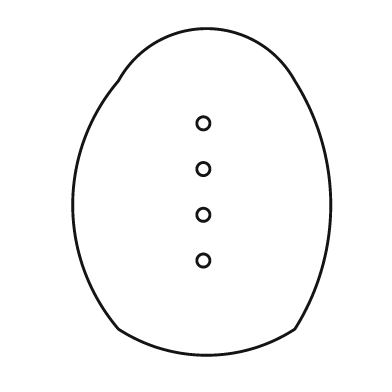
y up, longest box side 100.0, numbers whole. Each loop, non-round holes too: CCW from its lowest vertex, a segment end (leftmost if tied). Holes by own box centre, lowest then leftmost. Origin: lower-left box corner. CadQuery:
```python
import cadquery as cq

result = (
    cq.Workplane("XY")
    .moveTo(14.0, 8.0)
    .threePointArc((41.0, 0.0), (68.0, 8.0))
    .threePointArc((79.0, 46.0), (68.0, 84.0))
    .threePointArc((41.0, 100.0), (14.0, 84.0))
    .threePointArc((0.0, 46.0), (14.0, 8.0))
    .close()
    .moveTo(40.0, 29.0)
    .circle(2.0)
    .moveTo(40.0, 43.0)
    .circle(2.0)
    .moveTo(40.0, 57.0)
    .circle(2.0)
    .moveTo(40.0, 71.0)
    .circle(2.0)
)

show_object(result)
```